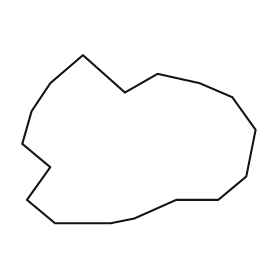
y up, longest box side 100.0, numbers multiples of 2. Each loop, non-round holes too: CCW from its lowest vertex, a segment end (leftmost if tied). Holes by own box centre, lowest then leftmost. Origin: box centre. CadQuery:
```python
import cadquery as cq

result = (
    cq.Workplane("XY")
    .moveTo(-36.0, -36.0)
    .lineTo(-12.0, -36.0)
    .lineTo(-2.0, -34.0)
    .lineTo(16.0, -26.0)
    .lineTo(34.0, -26.0)
    .lineTo(46.0, -16.0)
    .lineTo(50.0, 4.0)
    .lineTo(40.0, 18.0)
    .lineTo(26.0, 24.0)
    .lineTo(8.0, 28.0)
    .lineTo(-6.0, 20.0)
    .lineTo(-24.0, 36.0)
    .lineTo(-38.0, 24.0)
    .lineTo(-46.0, 12.0)
    .lineTo(-50.0, -2.0)
    .lineTo(-38.0, -12.0)
    .lineTo(-48.0, -26.0)
    .close()
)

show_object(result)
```